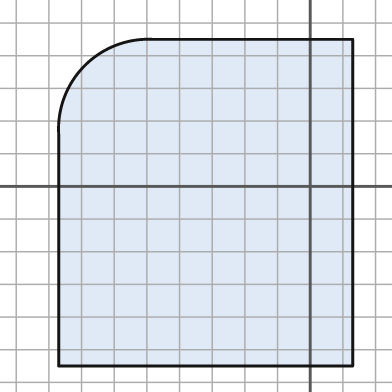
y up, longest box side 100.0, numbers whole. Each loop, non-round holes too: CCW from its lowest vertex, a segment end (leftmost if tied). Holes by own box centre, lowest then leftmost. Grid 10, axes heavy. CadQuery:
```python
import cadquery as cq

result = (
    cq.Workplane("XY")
    .moveTo(-77.0, -55.0)
    .lineTo(13.0, -55.0)
    .lineTo(13.0, 45.0)
    .lineTo(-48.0, 45.0)
    .threePointArc((-69.0, 37.0), (-77.0, 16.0))
    .close()
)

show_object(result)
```